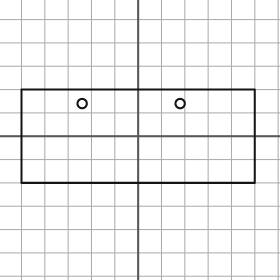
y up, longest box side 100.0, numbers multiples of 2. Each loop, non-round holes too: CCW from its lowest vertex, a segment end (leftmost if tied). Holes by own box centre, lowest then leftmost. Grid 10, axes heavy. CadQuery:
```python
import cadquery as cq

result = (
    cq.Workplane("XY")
    .moveTo(-50.0, -20.0)
    .lineTo(50.0, -20.0)
    .lineTo(50.0, 20.0)
    .lineTo(-50.0, 20.0)
    .close()
    .moveTo(-24.0, 14.0)
    .circle(2.0)
    .moveTo(18.0, 14.0)
    .circle(2.0)
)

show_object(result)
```